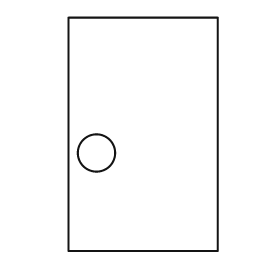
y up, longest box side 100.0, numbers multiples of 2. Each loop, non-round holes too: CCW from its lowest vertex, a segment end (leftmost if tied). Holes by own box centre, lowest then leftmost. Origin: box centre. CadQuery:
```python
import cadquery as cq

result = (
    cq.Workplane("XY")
    .moveTo(-32.0, -50.0)
    .lineTo(32.0, -50.0)
    .lineTo(32.0, 50.0)
    .lineTo(-32.0, 50.0)
    .close()
    .moveTo(-20.0, -8.0)
    .circle(8.0)
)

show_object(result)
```